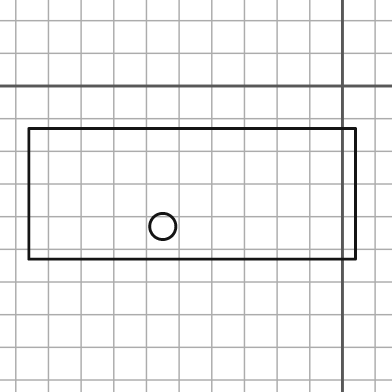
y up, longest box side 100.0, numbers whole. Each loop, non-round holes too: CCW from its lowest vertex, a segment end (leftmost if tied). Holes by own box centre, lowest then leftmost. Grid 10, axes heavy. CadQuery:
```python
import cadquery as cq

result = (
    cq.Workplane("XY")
    .moveTo(-96.0, -53.0)
    .lineTo(4.0, -53.0)
    .lineTo(4.0, -13.0)
    .lineTo(-96.0, -13.0)
    .close()
    .moveTo(-55.0, -43.0)
    .circle(4.0)
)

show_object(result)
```